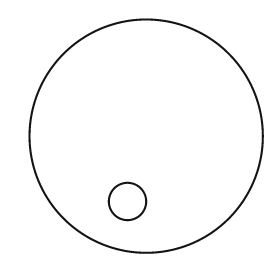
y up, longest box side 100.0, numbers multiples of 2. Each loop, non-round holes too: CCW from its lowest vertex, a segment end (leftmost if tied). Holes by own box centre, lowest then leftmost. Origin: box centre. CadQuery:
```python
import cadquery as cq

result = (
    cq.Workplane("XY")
    .moveTo(0.0, 0.0)
    .circle(50.0)
    .moveTo(-8.0, -28.0)
    .circle(8.0)
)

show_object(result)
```